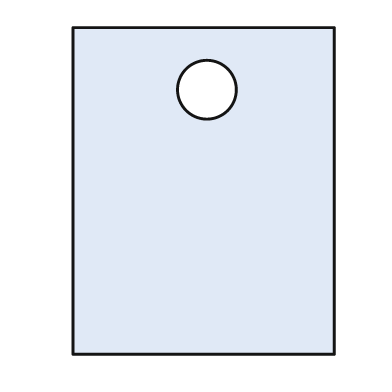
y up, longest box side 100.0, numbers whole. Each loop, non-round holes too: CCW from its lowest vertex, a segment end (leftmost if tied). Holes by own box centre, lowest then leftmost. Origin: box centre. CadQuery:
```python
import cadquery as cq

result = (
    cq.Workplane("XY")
    .moveTo(-40.0, -50.0)
    .lineTo(40.0, -50.0)
    .lineTo(40.0, 50.0)
    .lineTo(-40.0, 50.0)
    .close()
    .moveTo(1.0, 31.0)
    .circle(9.0)
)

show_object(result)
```